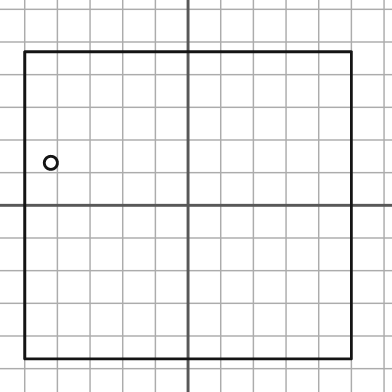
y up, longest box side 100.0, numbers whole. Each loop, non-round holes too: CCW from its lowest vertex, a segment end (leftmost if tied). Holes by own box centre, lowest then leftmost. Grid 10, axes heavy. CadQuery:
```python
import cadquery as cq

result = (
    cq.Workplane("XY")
    .moveTo(-50.0, -47.0)
    .lineTo(50.0, -47.0)
    .lineTo(50.0, 47.0)
    .lineTo(-50.0, 47.0)
    .close()
    .moveTo(-42.0, 13.0)
    .circle(2.0)
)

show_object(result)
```